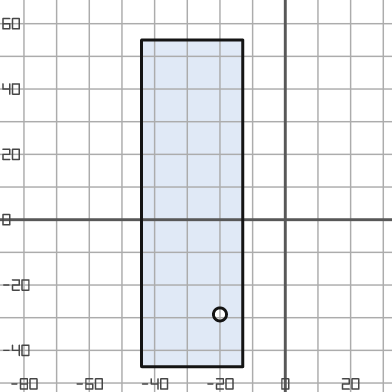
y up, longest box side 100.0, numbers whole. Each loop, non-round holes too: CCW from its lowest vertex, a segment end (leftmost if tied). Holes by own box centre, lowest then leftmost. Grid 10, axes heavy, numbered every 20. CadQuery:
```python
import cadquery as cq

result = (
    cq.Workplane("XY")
    .moveTo(-44.0, -45.0)
    .lineTo(-13.0, -45.0)
    .lineTo(-13.0, 55.0)
    .lineTo(-44.0, 55.0)
    .close()
    .moveTo(-20.0, -29.0)
    .circle(2.0)
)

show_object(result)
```